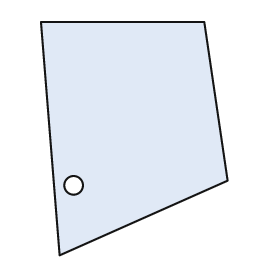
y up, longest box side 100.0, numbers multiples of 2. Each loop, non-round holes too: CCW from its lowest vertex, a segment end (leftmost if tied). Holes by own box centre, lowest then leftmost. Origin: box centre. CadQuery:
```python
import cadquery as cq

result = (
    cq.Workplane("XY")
    .moveTo(-32.0, -50.0)
    .lineTo(40.0, -18.0)
    .lineTo(30.0, 50.0)
    .lineTo(-40.0, 50.0)
    .close()
    .moveTo(-26.0, -20.0)
    .circle(4.0)
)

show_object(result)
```